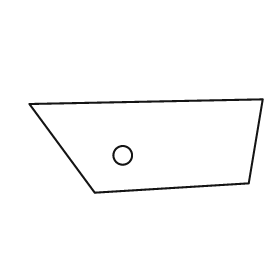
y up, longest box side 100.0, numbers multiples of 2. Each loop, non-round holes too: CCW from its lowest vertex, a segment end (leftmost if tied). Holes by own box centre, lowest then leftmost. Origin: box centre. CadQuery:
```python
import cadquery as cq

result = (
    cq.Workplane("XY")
    .moveTo(-22.0, -20.0)
    .lineTo(44.0, -16.0)
    .lineTo(50.0, 20.0)
    .lineTo(-50.0, 18.0)
    .close()
    .moveTo(-10.0, -4.0)
    .circle(4.0)
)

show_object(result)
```